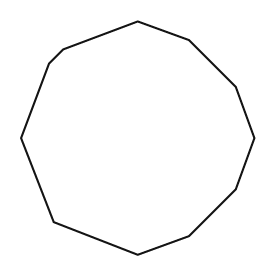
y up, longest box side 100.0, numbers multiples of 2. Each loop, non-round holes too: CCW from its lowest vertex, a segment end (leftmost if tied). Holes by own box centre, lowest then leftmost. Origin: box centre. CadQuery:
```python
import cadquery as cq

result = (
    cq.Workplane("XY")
    .moveTo(0.0, -50.0)
    .lineTo(22.0, -42.0)
    .lineTo(42.0, -22.0)
    .lineTo(50.0, 0.0)
    .lineTo(42.0, 22.0)
    .lineTo(22.0, 42.0)
    .lineTo(0.0, 50.0)
    .lineTo(-32.0, 38.0)
    .lineTo(-38.0, 32.0)
    .lineTo(-50.0, 0.0)
    .lineTo(-36.0, -36.0)
    .close()
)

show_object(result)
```